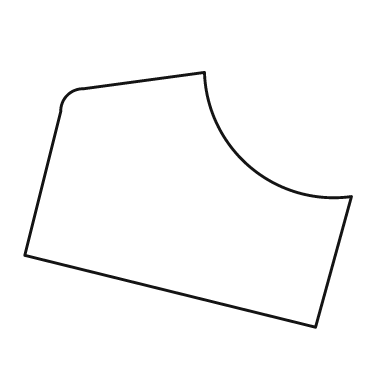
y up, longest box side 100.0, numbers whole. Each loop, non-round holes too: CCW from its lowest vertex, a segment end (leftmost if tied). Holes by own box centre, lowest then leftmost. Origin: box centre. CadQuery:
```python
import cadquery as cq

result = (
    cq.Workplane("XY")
    .moveTo(39.0, -39.0)
    .lineTo(50.0, 1.0)
    .threePointArc((19.0, 10.0), (5.0, 39.0))
    .lineTo(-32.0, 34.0)
    .threePointArc((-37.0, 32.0), (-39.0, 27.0))
    .lineTo(-50.0, -17.0)
    .close()
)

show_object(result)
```